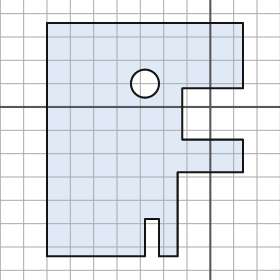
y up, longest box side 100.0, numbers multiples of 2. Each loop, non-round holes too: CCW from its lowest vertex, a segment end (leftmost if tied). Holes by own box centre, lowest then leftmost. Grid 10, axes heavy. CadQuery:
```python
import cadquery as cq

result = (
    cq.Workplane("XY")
    .moveTo(-70.0, -64.0)
    .lineTo(-28.0, -64.0)
    .lineTo(-28.0, -48.0)
    .lineTo(-22.0, -48.0)
    .lineTo(-22.0, -64.0)
    .lineTo(-14.0, -64.0)
    .lineTo(-14.0, -28.0)
    .lineTo(14.0, -28.0)
    .lineTo(14.0, -14.0)
    .lineTo(-12.0, -14.0)
    .lineTo(-12.0, 8.0)
    .lineTo(14.0, 8.0)
    .lineTo(14.0, 36.0)
    .lineTo(-70.0, 36.0)
    .close()
    .moveTo(-28.0, 10.0)
    .circle(6.0)
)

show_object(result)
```